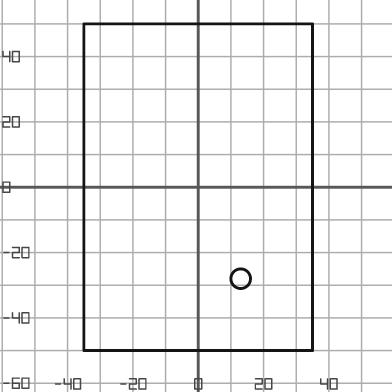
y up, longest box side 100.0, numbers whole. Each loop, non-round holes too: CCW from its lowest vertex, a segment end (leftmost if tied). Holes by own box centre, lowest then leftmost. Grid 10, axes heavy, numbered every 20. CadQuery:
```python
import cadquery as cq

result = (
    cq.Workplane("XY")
    .moveTo(-35.0, -50.0)
    .lineTo(35.0, -50.0)
    .lineTo(35.0, 50.0)
    .lineTo(-35.0, 50.0)
    .close()
    .moveTo(13.0, -28.0)
    .circle(3.0)
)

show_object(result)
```